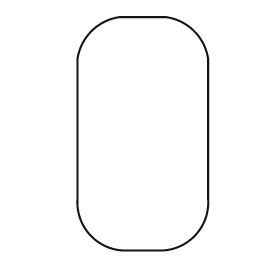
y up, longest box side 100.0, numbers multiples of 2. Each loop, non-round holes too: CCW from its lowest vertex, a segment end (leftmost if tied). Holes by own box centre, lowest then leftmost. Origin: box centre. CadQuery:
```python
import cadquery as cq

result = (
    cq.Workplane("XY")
    .moveTo(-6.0, -50.0)
    .lineTo(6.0, -50.0)
    .threePointArc((22.0, -44.0), (28.0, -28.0))
    .lineTo(28.0, 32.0)
    .threePointArc((22.0, 44.0), (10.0, 50.0))
    .lineTo(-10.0, 50.0)
    .threePointArc((-22.0, 44.0), (-28.0, 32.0))
    .lineTo(-28.0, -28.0)
    .threePointArc((-22.0, -44.0), (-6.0, -50.0))
    .close()
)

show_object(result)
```